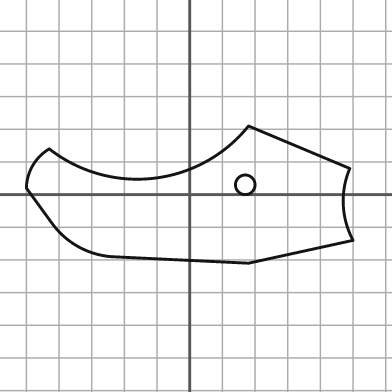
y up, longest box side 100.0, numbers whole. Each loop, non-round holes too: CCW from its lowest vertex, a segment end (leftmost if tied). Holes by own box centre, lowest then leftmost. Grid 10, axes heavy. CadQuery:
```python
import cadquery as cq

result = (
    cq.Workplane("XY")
    .moveTo(18.0, -21.0)
    .lineTo(50.0, -14.0)
    .threePointArc((47.0, -3.0), (49.0, 8.0))
    .lineTo(18.0, 21.0)
    .threePointArc((-11.0, 5.0), (-43.0, 14.0))
    .threePointArc((-48.0, 9.0), (-50.0, 2.0))
    .lineTo(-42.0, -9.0)
    .threePointArc((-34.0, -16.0), (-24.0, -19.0))
    .close()
    .moveTo(17.0, 3.0)
    .circle(3.0)
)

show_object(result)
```